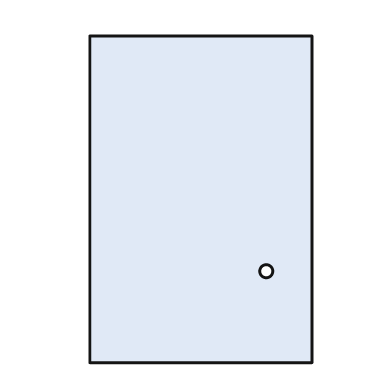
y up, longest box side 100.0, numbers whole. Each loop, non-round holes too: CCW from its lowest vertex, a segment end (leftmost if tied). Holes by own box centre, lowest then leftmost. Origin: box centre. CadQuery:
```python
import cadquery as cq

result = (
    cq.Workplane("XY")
    .moveTo(-34.0, -50.0)
    .lineTo(34.0, -50.0)
    .lineTo(34.0, 50.0)
    .lineTo(-34.0, 50.0)
    .close()
    .moveTo(20.0, -22.0)
    .circle(2.0)
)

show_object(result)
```